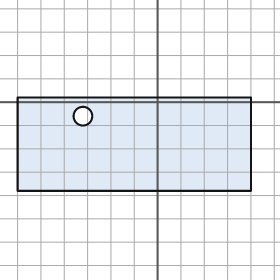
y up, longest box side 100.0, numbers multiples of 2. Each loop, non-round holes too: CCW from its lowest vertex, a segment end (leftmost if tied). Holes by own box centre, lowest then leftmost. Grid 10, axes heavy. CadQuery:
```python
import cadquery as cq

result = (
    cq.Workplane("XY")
    .moveTo(-60.0, -38.0)
    .lineTo(40.0, -38.0)
    .lineTo(40.0, 2.0)
    .lineTo(-60.0, 2.0)
    .close()
    .moveTo(-32.0, -6.0)
    .circle(4.0)
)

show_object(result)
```